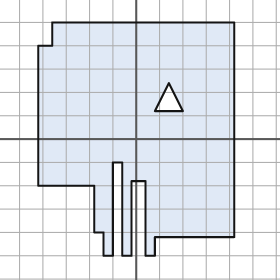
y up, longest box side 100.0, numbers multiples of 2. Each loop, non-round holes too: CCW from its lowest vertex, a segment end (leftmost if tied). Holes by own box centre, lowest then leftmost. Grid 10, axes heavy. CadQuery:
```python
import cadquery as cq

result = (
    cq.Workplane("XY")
    .moveTo(-14.0, -50.0)
    .lineTo(-10.0, -50.0)
    .lineTo(-10.0, -10.0)
    .lineTo(-6.0, -10.0)
    .lineTo(-6.0, -50.0)
    .lineTo(-2.0, -50.0)
    .lineTo(-2.0, -18.0)
    .lineTo(4.0, -18.0)
    .lineTo(4.0, -50.0)
    .lineTo(8.0, -50.0)
    .lineTo(8.0, -42.0)
    .lineTo(42.0, -42.0)
    .lineTo(42.0, 50.0)
    .lineTo(-36.0, 50.0)
    .lineTo(-36.0, 40.0)
    .lineTo(-42.0, 40.0)
    .lineTo(-42.0, -20.0)
    .lineTo(-18.0, -20.0)
    .lineTo(-18.0, -40.0)
    .lineTo(-14.0, -40.0)
    .close()
    .moveTo(8.0, 12.0)
    .lineTo(20.0, 12.0)
    .lineTo(14.0, 24.0)
    .close()
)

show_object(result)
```